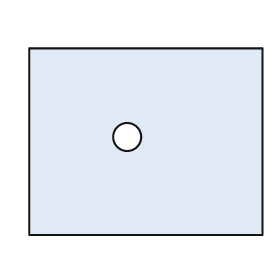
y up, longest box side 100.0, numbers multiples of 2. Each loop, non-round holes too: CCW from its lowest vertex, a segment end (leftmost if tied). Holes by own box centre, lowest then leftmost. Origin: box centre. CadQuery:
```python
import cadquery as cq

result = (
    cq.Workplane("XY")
    .moveTo(-50.0, -40.0)
    .lineTo(50.0, -40.0)
    .lineTo(50.0, 40.0)
    .lineTo(-50.0, 40.0)
    .close()
    .moveTo(-8.0, 2.0)
    .circle(6.0)
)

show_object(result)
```